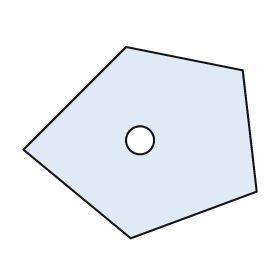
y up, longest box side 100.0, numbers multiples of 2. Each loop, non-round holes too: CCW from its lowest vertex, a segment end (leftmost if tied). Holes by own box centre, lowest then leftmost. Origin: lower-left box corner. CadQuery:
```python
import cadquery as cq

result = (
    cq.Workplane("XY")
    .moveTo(46.0, 0.0)
    .lineTo(100.0, 20.0)
    .lineTo(94.0, 72.0)
    .lineTo(44.0, 82.0)
    .lineTo(0.0, 38.0)
    .close()
    .moveTo(50.0, 42.0)
    .circle(6.0)
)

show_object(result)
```